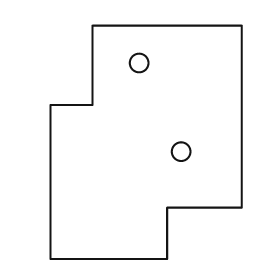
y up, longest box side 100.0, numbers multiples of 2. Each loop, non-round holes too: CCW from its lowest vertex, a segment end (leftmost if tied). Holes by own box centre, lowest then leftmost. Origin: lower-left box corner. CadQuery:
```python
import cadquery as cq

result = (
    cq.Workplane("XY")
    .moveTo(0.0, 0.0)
    .lineTo(50.0, 0.0)
    .lineTo(50.0, 22.0)
    .lineTo(82.0, 22.0)
    .lineTo(82.0, 100.0)
    .lineTo(18.0, 100.0)
    .lineTo(18.0, 66.0)
    .lineTo(0.0, 66.0)
    .close()
    .moveTo(56.0, 46.0)
    .circle(4.0)
    .moveTo(38.0, 84.0)
    .circle(4.0)
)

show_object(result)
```